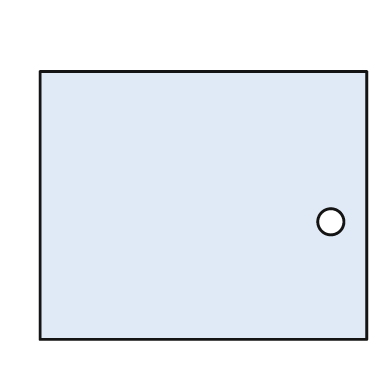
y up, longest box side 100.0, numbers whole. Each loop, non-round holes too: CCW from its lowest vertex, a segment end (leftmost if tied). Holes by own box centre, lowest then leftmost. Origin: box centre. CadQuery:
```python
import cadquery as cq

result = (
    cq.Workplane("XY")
    .moveTo(-50.0, -41.0)
    .lineTo(50.0, -41.0)
    .lineTo(50.0, 41.0)
    .lineTo(-50.0, 41.0)
    .close()
    .moveTo(39.0, -5.0)
    .circle(4.0)
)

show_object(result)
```